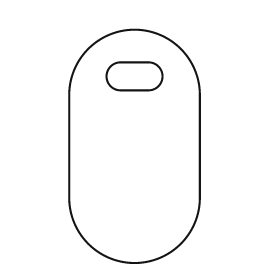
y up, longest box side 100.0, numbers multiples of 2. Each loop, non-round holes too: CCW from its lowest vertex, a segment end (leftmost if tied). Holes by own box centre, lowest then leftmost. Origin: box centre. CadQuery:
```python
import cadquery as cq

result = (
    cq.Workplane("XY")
    .moveTo(-28.0, -22.0)
    .threePointArc((0.0, -50.0), (28.0, -22.0))
    .lineTo(28.0, 22.0)
    .threePointArc((0.0, 50.0), (-28.0, 22.0))
    .close()
    .moveTo(-6.0, 24.0)
    .lineTo(6.0, 24.0)
    .threePointArc((12.0, 30.0), (6.0, 36.0))
    .lineTo(-6.0, 36.0)
    .threePointArc((-12.0, 30.0), (-6.0, 24.0))
    .close()
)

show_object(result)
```